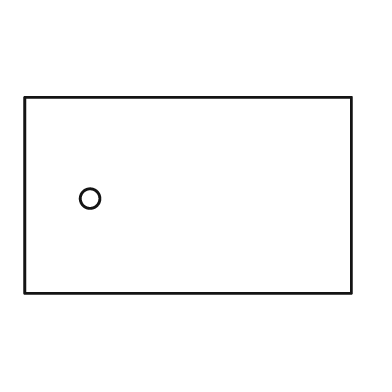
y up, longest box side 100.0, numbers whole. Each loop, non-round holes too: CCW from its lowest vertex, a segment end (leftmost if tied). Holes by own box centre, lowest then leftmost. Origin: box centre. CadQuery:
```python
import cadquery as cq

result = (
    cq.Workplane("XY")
    .moveTo(-50.0, -30.0)
    .lineTo(50.0, -30.0)
    .lineTo(50.0, 30.0)
    .lineTo(-50.0, 30.0)
    .close()
    .moveTo(-30.0, -1.0)
    .circle(3.0)
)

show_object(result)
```